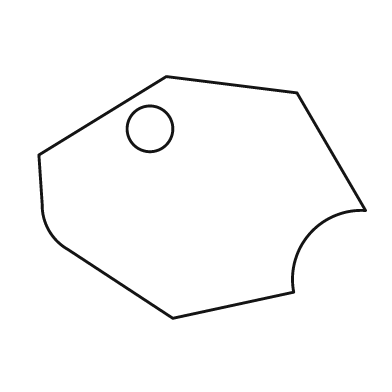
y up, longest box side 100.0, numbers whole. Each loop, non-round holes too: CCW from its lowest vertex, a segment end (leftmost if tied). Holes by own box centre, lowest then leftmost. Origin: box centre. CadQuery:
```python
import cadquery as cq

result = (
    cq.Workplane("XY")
    .moveTo(-9.0, -37.0)
    .lineTo(28.0, -29.0)
    .threePointArc((33.0, -11.0), (50.0, -4.0))
    .lineTo(29.0, 32.0)
    .lineTo(-11.0, 37.0)
    .lineTo(-50.0, 13.0)
    .lineTo(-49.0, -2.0)
    .threePointArc((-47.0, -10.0), (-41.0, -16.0))
    .close()
    .moveTo(-16.0, 21.0)
    .circle(7.0)
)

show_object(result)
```